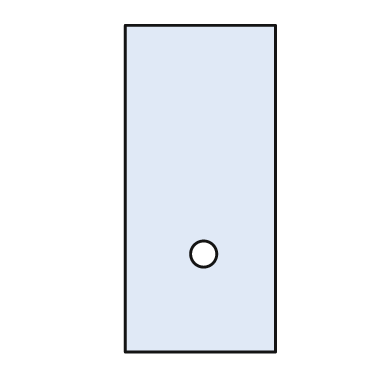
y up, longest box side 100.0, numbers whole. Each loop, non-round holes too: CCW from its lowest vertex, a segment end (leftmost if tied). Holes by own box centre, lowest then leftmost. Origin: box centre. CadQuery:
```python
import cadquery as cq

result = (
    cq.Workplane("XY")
    .moveTo(-23.0, -50.0)
    .lineTo(23.0, -50.0)
    .lineTo(23.0, 50.0)
    .lineTo(-23.0, 50.0)
    .close()
    .moveTo(1.0, -20.0)
    .circle(4.0)
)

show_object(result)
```